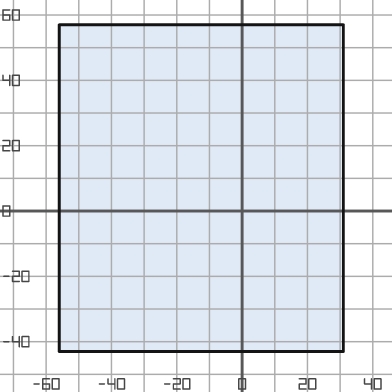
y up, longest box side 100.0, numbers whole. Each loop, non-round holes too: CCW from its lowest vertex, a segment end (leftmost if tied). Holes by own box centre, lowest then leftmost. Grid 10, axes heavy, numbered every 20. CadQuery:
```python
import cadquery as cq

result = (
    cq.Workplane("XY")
    .moveTo(-56.0, -43.0)
    .lineTo(31.0, -43.0)
    .lineTo(31.0, 57.0)
    .lineTo(-56.0, 57.0)
    .close()
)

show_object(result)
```